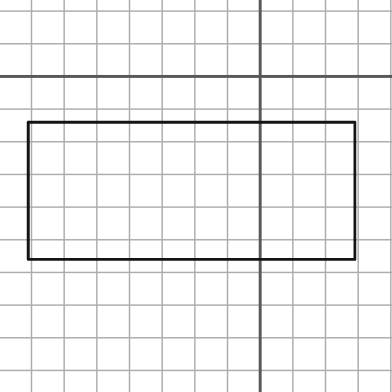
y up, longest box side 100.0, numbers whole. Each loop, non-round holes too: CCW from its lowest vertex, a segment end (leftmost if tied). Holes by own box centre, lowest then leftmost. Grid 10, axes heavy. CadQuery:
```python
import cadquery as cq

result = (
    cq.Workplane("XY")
    .moveTo(-71.0, -56.0)
    .lineTo(29.0, -56.0)
    .lineTo(29.0, -14.0)
    .lineTo(-71.0, -14.0)
    .close()
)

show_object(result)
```